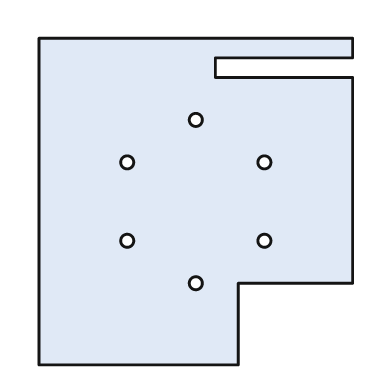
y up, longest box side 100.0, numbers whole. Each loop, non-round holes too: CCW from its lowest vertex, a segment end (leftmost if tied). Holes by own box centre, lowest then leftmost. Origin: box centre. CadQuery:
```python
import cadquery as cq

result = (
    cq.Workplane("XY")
    .moveTo(-48.0, -50.0)
    .lineTo(13.0, -50.0)
    .lineTo(13.0, -25.0)
    .lineTo(48.0, -25.0)
    .lineTo(48.0, 38.0)
    .lineTo(6.0, 38.0)
    .lineTo(6.0, 44.0)
    .lineTo(48.0, 44.0)
    .lineTo(48.0, 50.0)
    .lineTo(-48.0, 50.0)
    .close()
    .moveTo(0.0, -25.0)
    .circle(2.0)
    .moveTo(-21.0, -12.0)
    .circle(2.0)
    .moveTo(21.0, -12.0)
    .circle(2.0)
    .moveTo(-21.0, 12.0)
    .circle(2.0)
    .moveTo(21.0, 12.0)
    .circle(2.0)
    .moveTo(0.0, 25.0)
    .circle(2.0)
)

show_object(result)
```